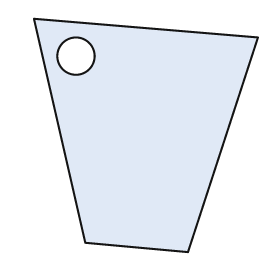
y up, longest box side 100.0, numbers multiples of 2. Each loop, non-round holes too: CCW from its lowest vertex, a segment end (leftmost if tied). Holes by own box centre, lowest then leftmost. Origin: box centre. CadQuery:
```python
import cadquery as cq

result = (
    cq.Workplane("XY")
    .moveTo(18.0, -50.0)
    .lineTo(48.0, 42.0)
    .lineTo(-48.0, 50.0)
    .lineTo(-26.0, -46.0)
    .close()
    .moveTo(-30.0, 34.0)
    .circle(8.0)
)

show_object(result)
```